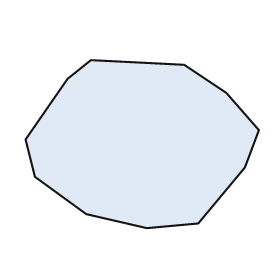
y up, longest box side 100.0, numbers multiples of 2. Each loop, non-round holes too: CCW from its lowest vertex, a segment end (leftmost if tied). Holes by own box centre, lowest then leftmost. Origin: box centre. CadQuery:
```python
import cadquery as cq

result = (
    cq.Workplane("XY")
    .moveTo(2.0, -36.0)
    .lineTo(24.0, -34.0)
    .lineTo(44.0, -10.0)
    .lineTo(50.0, 6.0)
    .lineTo(36.0, 22.0)
    .lineTo(18.0, 34.0)
    .lineTo(-22.0, 36.0)
    .lineTo(-32.0, 28.0)
    .lineTo(-50.0, 2.0)
    .lineTo(-46.0, -14.0)
    .lineTo(-24.0, -30.0)
    .close()
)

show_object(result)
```